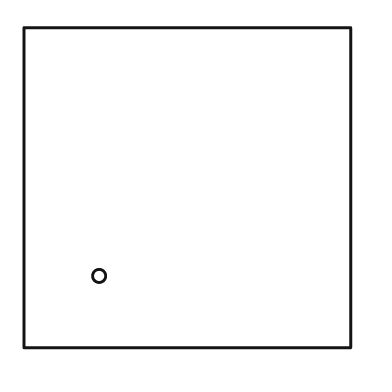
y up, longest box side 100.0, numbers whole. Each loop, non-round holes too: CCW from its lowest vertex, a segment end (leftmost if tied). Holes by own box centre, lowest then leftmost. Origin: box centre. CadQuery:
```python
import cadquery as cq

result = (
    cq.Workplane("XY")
    .moveTo(-50.0, -49.0)
    .lineTo(50.0, -49.0)
    .lineTo(50.0, 49.0)
    .lineTo(-50.0, 49.0)
    .close()
    .moveTo(-27.0, -27.0)
    .circle(2.0)
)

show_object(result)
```